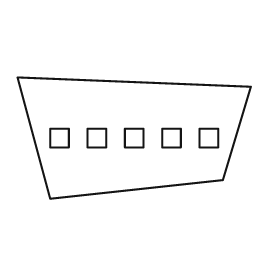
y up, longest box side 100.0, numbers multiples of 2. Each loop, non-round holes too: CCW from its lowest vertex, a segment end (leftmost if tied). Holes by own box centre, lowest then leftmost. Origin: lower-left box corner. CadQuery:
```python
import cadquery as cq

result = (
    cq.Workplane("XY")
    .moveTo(14.0, 0.0)
    .lineTo(88.0, 8.0)
    .lineTo(100.0, 48.0)
    .lineTo(0.0, 52.0)
    .close()
    .moveTo(14.0, 22.0)
    .lineTo(22.0, 22.0)
    .lineTo(22.0, 30.0)
    .lineTo(14.0, 30.0)
    .close()
    .moveTo(30.0, 22.0)
    .lineTo(38.0, 22.0)
    .lineTo(38.0, 30.0)
    .lineTo(30.0, 30.0)
    .close()
    .moveTo(46.0, 22.0)
    .lineTo(54.0, 22.0)
    .lineTo(54.0, 30.0)
    .lineTo(46.0, 30.0)
    .close()
    .moveTo(62.0, 22.0)
    .lineTo(70.0, 22.0)
    .lineTo(70.0, 30.0)
    .lineTo(62.0, 30.0)
    .close()
    .moveTo(78.0, 22.0)
    .lineTo(86.0, 22.0)
    .lineTo(86.0, 30.0)
    .lineTo(78.0, 30.0)
    .close()
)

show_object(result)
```